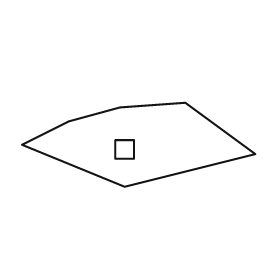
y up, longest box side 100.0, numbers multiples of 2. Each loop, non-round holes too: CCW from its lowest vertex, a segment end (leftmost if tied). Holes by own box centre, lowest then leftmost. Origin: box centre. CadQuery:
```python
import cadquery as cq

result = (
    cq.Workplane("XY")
    .moveTo(-6.0, -18.0)
    .lineTo(50.0, -4.0)
    .lineTo(20.0, 18.0)
    .lineTo(-8.0, 16.0)
    .lineTo(-30.0, 10.0)
    .lineTo(-50.0, 0.0)
    .close()
    .moveTo(-10.0, -6.0)
    .lineTo(-2.0, -6.0)
    .lineTo(-2.0, 2.0)
    .lineTo(-10.0, 2.0)
    .close()
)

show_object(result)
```